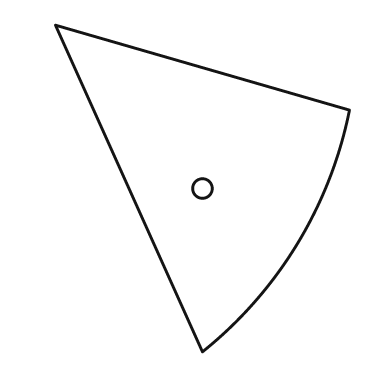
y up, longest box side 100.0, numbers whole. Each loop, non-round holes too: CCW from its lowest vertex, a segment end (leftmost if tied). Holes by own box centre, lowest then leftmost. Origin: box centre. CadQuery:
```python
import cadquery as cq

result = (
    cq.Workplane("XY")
    .moveTo(0.0, -50.0)
    .threePointArc((29.0, -17.0), (45.0, 24.0))
    .lineTo(-45.0, 50.0)
    .close()
    .moveTo(0.0, 0.0)
    .circle(3.0)
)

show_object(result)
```